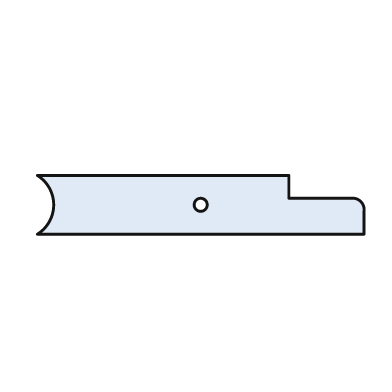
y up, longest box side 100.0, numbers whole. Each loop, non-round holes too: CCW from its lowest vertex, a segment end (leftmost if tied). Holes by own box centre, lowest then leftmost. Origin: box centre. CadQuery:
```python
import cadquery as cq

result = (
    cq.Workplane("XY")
    .moveTo(-50.0, -9.0)
    .lineTo(50.0, -9.0)
    .lineTo(50.0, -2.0)
    .threePointArc((49.0, 1.0), (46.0, 2.0))
    .lineTo(27.0, 2.0)
    .lineTo(27.0, 9.0)
    .lineTo(-50.0, 9.0)
    .threePointArc((-45.0, 0.0), (-50.0, -9.0))
    .close()
    .moveTo(0.0, 0.0)
    .circle(2.0)
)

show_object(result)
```